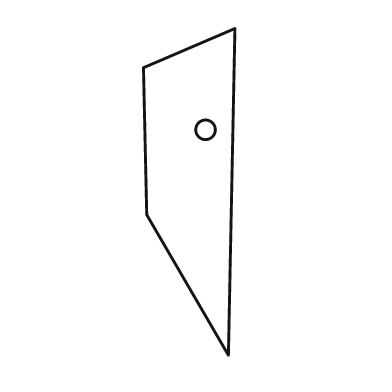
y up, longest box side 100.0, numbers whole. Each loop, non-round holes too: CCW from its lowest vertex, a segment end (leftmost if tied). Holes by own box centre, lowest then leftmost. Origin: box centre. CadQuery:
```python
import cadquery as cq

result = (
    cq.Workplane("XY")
    .moveTo(12.0, -50.0)
    .lineTo(14.0, 50.0)
    .lineTo(-14.0, 38.0)
    .lineTo(-13.0, -7.0)
    .close()
    .moveTo(5.0, 19.0)
    .circle(3.0)
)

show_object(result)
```